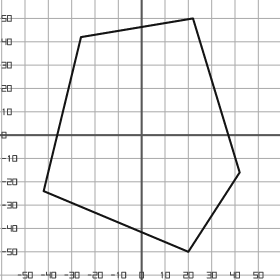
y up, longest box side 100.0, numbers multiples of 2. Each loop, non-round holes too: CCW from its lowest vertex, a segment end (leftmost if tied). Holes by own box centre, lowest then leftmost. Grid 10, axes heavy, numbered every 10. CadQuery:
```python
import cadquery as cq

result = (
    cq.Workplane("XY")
    .moveTo(20.0, -50.0)
    .lineTo(42.0, -16.0)
    .lineTo(22.0, 50.0)
    .lineTo(-26.0, 42.0)
    .lineTo(-42.0, -24.0)
    .close()
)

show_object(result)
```